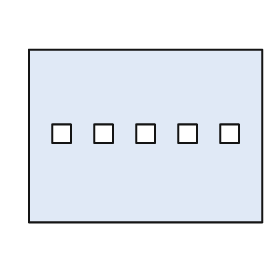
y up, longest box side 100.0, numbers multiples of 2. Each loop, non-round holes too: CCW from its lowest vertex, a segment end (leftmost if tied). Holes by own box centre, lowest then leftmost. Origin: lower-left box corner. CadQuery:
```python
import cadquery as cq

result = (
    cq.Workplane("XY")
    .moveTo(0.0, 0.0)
    .lineTo(100.0, 0.0)
    .lineTo(100.0, 74.0)
    .lineTo(0.0, 74.0)
    .close()
    .moveTo(10.0, 34.0)
    .lineTo(18.0, 34.0)
    .lineTo(18.0, 42.0)
    .lineTo(10.0, 42.0)
    .close()
    .moveTo(28.0, 34.0)
    .lineTo(36.0, 34.0)
    .lineTo(36.0, 42.0)
    .lineTo(28.0, 42.0)
    .close()
    .moveTo(46.0, 34.0)
    .lineTo(54.0, 34.0)
    .lineTo(54.0, 42.0)
    .lineTo(46.0, 42.0)
    .close()
    .moveTo(64.0, 34.0)
    .lineTo(72.0, 34.0)
    .lineTo(72.0, 42.0)
    .lineTo(64.0, 42.0)
    .close()
    .moveTo(82.0, 34.0)
    .lineTo(90.0, 34.0)
    .lineTo(90.0, 42.0)
    .lineTo(82.0, 42.0)
    .close()
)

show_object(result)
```